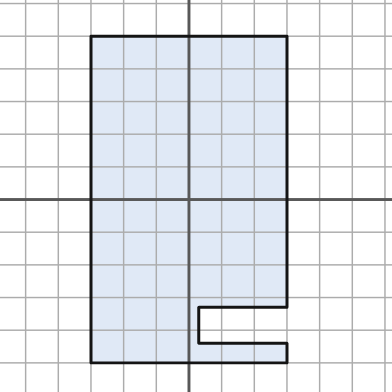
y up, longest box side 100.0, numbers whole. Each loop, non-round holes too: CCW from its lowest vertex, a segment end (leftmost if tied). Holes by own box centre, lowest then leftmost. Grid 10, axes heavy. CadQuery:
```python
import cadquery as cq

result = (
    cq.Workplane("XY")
    .moveTo(-30.0, -50.0)
    .lineTo(30.0, -50.0)
    .lineTo(30.0, -44.0)
    .lineTo(3.0, -44.0)
    .lineTo(3.0, -33.0)
    .lineTo(30.0, -33.0)
    .lineTo(30.0, 50.0)
    .lineTo(-30.0, 50.0)
    .close()
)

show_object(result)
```